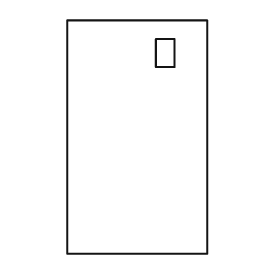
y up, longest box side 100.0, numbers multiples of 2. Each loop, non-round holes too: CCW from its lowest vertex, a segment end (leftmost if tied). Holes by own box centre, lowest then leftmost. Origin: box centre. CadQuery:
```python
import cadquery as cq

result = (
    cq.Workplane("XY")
    .moveTo(-30.0, -50.0)
    .lineTo(30.0, -50.0)
    .lineTo(30.0, 50.0)
    .lineTo(-30.0, 50.0)
    .close()
    .moveTo(8.0, 30.0)
    .lineTo(16.0, 30.0)
    .lineTo(16.0, 42.0)
    .lineTo(8.0, 42.0)
    .close()
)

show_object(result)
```